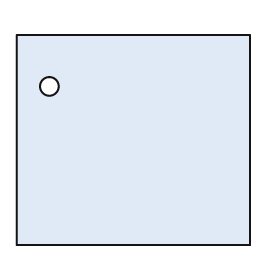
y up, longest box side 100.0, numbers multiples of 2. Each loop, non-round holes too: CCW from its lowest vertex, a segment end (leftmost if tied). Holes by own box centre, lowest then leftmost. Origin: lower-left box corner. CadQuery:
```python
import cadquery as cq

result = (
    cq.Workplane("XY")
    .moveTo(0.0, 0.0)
    .lineTo(100.0, 0.0)
    .lineTo(100.0, 90.0)
    .lineTo(0.0, 90.0)
    .close()
    .moveTo(14.0, 68.0)
    .circle(4.0)
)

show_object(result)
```